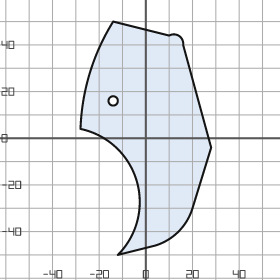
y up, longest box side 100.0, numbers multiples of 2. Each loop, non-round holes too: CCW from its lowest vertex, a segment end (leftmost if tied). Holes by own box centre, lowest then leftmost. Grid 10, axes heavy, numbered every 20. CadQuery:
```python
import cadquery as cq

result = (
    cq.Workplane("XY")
    .moveTo(-12.0, -50.0)
    .lineTo(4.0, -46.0)
    .threePointArc((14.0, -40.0), (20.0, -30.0))
    .lineTo(28.0, -4.0)
    .lineTo(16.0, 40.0)
    .threePointArc((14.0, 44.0), (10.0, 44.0))
    .lineTo(-14.0, 50.0)
    .threePointArc((-24.0, 28.0), (-28.0, 4.0))
    .threePointArc((-4.0, -18.0), (-12.0, -50.0))
    .close()
    .moveTo(-14.0, 16.0)
    .circle(2.0)
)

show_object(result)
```